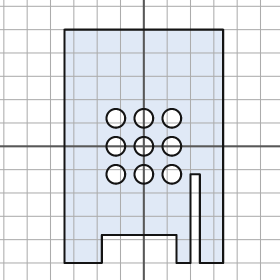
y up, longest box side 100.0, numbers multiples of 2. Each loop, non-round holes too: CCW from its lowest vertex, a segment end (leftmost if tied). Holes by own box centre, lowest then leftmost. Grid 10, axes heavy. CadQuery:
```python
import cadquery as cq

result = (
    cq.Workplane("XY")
    .moveTo(-34.0, -50.0)
    .lineTo(-18.0, -50.0)
    .lineTo(-18.0, -38.0)
    .lineTo(14.0, -38.0)
    .lineTo(14.0, -50.0)
    .lineTo(20.0, -50.0)
    .lineTo(20.0, -12.0)
    .lineTo(24.0, -12.0)
    .lineTo(24.0, -50.0)
    .lineTo(34.0, -50.0)
    .lineTo(34.0, 50.0)
    .lineTo(-34.0, 50.0)
    .close()
    .moveTo(-12.0, -12.0)
    .circle(4.0)
    .moveTo(0.0, -12.0)
    .circle(4.0)
    .moveTo(12.0, -12.0)
    .circle(4.0)
    .moveTo(-12.0, 0.0)
    .circle(4.0)
    .moveTo(0.0, 0.0)
    .circle(4.0)
    .moveTo(12.0, 0.0)
    .circle(4.0)
    .moveTo(-12.0, 12.0)
    .circle(4.0)
    .moveTo(0.0, 12.0)
    .circle(4.0)
    .moveTo(12.0, 12.0)
    .circle(4.0)
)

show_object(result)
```